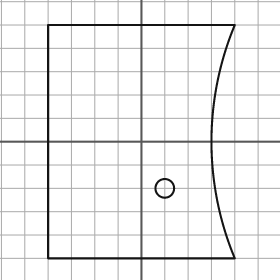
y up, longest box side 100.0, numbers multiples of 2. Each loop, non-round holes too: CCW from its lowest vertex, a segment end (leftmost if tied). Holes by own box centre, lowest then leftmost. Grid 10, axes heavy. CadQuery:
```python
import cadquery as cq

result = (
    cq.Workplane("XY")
    .moveTo(-40.0, -50.0)
    .lineTo(40.0, -50.0)
    .threePointArc((30.0, 0.0), (40.0, 50.0))
    .lineTo(-40.0, 50.0)
    .close()
    .moveTo(10.0, -20.0)
    .circle(4.0)
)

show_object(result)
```